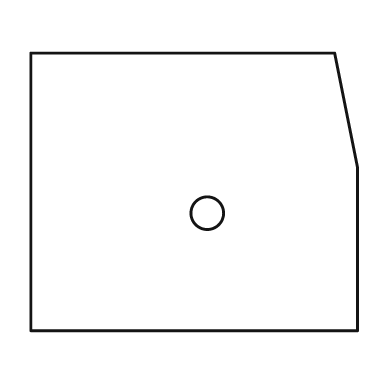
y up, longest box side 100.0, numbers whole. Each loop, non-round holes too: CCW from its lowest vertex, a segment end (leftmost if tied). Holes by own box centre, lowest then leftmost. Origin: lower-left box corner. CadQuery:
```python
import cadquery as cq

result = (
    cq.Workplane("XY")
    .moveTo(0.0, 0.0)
    .lineTo(100.0, 0.0)
    .lineTo(100.0, 50.0)
    .lineTo(93.0, 85.0)
    .lineTo(0.0, 85.0)
    .close()
    .moveTo(54.0, 36.0)
    .circle(5.0)
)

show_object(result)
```